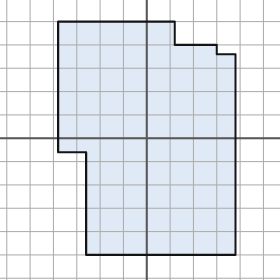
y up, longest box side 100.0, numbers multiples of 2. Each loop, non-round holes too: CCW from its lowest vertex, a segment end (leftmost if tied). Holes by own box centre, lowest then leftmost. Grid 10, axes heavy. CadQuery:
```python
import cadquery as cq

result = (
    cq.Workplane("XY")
    .moveTo(-26.0, -50.0)
    .lineTo(38.0, -50.0)
    .lineTo(38.0, 36.0)
    .lineTo(30.0, 36.0)
    .lineTo(30.0, 40.0)
    .lineTo(12.0, 40.0)
    .lineTo(12.0, 50.0)
    .lineTo(-38.0, 50.0)
    .lineTo(-38.0, -6.0)
    .lineTo(-26.0, -6.0)
    .close()
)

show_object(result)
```